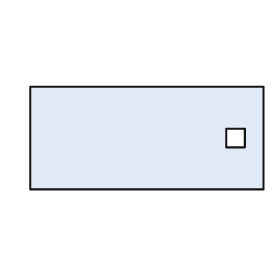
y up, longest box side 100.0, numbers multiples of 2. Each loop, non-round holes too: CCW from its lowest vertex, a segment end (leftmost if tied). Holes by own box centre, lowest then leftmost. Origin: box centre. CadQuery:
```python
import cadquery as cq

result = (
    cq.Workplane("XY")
    .moveTo(-50.0, -22.0)
    .lineTo(50.0, -22.0)
    .lineTo(50.0, 22.0)
    .lineTo(-50.0, 22.0)
    .close()
    .moveTo(34.0, -4.0)
    .lineTo(42.0, -4.0)
    .lineTo(42.0, 4.0)
    .lineTo(34.0, 4.0)
    .close()
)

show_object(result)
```